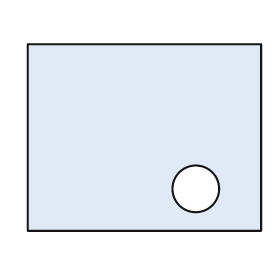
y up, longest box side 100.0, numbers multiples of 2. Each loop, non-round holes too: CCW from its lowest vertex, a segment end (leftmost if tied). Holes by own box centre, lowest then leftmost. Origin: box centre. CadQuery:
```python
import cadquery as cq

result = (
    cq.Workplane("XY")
    .moveTo(-50.0, -40.0)
    .lineTo(50.0, -40.0)
    .lineTo(50.0, 40.0)
    .lineTo(-50.0, 40.0)
    .close()
    .moveTo(22.0, -22.0)
    .circle(10.0)
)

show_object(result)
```